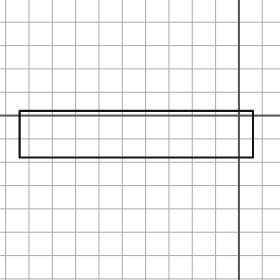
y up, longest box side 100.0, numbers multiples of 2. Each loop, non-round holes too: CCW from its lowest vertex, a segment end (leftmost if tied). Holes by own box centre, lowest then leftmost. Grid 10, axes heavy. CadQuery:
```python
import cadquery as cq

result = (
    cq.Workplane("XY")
    .moveTo(-94.0, -18.0)
    .lineTo(6.0, -18.0)
    .lineTo(6.0, 2.0)
    .lineTo(-94.0, 2.0)
    .close()
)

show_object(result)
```